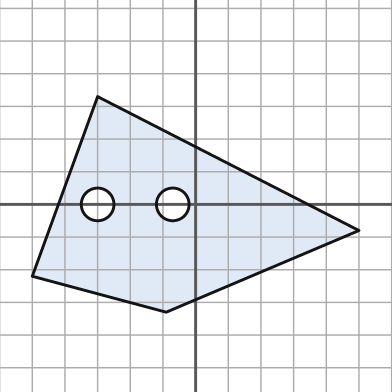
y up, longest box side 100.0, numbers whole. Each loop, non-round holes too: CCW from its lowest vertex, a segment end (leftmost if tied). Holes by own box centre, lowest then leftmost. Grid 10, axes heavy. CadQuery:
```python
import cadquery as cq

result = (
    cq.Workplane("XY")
    .moveTo(-9.0, -33.0)
    .lineTo(50.0, -8.0)
    .lineTo(-30.0, 33.0)
    .lineTo(-50.0, -22.0)
    .close()
    .moveTo(-30.0, 0.0)
    .circle(5.0)
    .moveTo(-7.0, 0.0)
    .circle(5.0)
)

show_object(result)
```